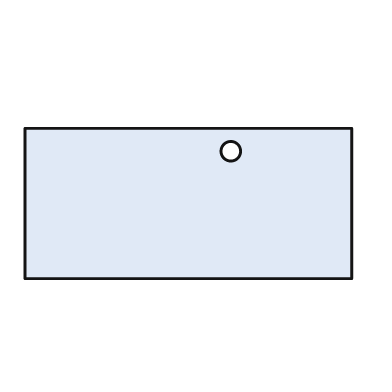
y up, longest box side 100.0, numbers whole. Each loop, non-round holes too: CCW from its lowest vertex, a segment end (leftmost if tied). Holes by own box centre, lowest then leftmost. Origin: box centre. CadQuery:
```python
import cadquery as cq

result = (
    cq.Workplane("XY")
    .moveTo(-50.0, -23.0)
    .lineTo(50.0, -23.0)
    .lineTo(50.0, 23.0)
    .lineTo(-50.0, 23.0)
    .close()
    .moveTo(13.0, 16.0)
    .circle(3.0)
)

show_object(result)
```